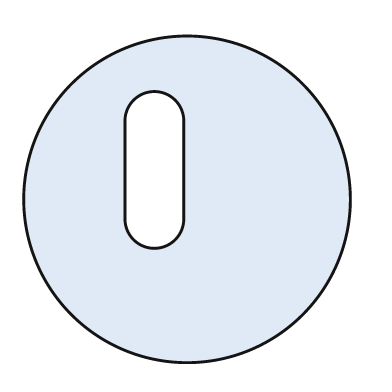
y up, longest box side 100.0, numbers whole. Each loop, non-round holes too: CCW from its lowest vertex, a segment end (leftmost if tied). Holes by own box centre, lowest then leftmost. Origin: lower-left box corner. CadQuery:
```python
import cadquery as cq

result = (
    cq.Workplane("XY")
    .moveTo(50.0, 50.0)
    .circle(50.0)
    .moveTo(31.0, 44.0)
    .threePointArc((40.0, 35.0), (49.0, 44.0))
    .lineTo(49.0, 74.0)
    .threePointArc((40.0, 83.0), (31.0, 74.0))
    .close()
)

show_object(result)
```